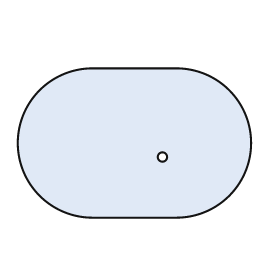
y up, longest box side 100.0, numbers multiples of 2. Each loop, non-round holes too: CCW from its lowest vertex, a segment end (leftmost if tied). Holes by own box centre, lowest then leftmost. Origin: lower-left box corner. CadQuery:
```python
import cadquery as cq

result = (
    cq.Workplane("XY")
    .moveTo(32.0, 0.0)
    .lineTo(68.0, 0.0)
    .threePointArc((100.0, 32.0), (68.0, 64.0))
    .lineTo(32.0, 64.0)
    .threePointArc((0.0, 32.0), (32.0, 0.0))
    .close()
    .moveTo(62.0, 26.0)
    .circle(2.0)
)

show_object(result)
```